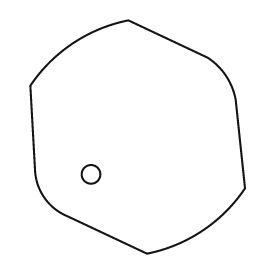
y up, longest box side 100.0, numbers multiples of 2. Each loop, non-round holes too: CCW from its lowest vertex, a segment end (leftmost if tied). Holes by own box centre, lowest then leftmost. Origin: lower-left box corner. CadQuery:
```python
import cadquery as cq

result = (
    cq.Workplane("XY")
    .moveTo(50.0, 0.0)
    .threePointArc((74.0, 10.0), (92.0, 28.0))
    .lineTo(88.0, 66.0)
    .threePointArc((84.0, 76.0), (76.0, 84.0))
    .lineTo(42.0, 100.0)
    .threePointArc((18.0, 90.0), (0.0, 72.0))
    .lineTo(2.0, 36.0)
    .threePointArc((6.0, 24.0), (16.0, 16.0))
    .close()
    .moveTo(26.0, 34.0)
    .circle(4.0)
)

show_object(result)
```